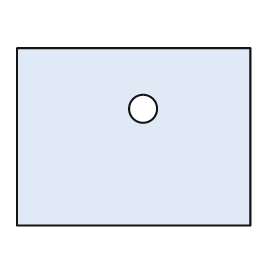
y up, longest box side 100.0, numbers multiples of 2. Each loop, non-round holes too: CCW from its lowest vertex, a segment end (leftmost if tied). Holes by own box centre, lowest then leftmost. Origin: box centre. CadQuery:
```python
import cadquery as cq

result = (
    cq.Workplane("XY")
    .moveTo(-50.0, -38.0)
    .lineTo(50.0, -38.0)
    .lineTo(50.0, 38.0)
    .lineTo(-50.0, 38.0)
    .close()
    .moveTo(4.0, 12.0)
    .circle(6.0)
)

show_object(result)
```